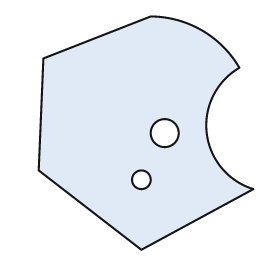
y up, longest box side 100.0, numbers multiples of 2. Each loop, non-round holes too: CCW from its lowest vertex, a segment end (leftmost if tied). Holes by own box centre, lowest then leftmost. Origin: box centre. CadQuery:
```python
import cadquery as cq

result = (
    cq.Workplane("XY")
    .moveTo(-2.0, -50.0)
    .lineTo(46.0, -24.0)
    .threePointArc((26.0, 0.0), (40.0, 28.0))
    .threePointArc((24.0, 44.0), (2.0, 50.0))
    .lineTo(-44.0, 32.0)
    .lineTo(-46.0, -16.0)
    .close()
    .moveTo(-2.0, -20.0)
    .circle(4.0)
    .moveTo(8.0, 0.0)
    .circle(6.0)
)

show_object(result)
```